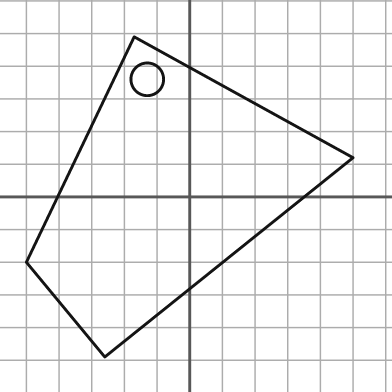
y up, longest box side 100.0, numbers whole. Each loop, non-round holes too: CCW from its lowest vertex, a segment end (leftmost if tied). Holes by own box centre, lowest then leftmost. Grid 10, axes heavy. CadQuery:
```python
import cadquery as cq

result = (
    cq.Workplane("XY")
    .moveTo(-26.0, -49.0)
    .lineTo(50.0, 12.0)
    .lineTo(-17.0, 49.0)
    .lineTo(-50.0, -20.0)
    .close()
    .moveTo(-13.0, 36.0)
    .circle(5.0)
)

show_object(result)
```